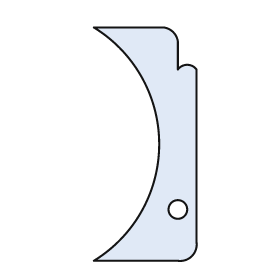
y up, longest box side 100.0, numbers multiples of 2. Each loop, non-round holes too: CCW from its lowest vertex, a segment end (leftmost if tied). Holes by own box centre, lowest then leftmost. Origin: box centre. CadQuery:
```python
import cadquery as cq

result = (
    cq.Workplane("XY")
    .moveTo(-22.0, -50.0)
    .lineTo(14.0, -50.0)
    .threePointArc((20.0, -48.0), (22.0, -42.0))
    .lineTo(22.0, 32.0)
    .threePointArc((18.0, 34.0), (14.0, 32.0))
    .lineTo(14.0, 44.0)
    .threePointArc((12.0, 48.0), (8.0, 50.0))
    .lineTo(-22.0, 50.0)
    .threePointArc((6.0, 0.0), (-22.0, -50.0))
    .close()
    .moveTo(14.0, -28.0)
    .circle(4.0)
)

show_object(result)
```